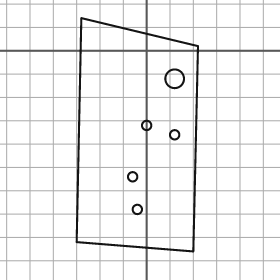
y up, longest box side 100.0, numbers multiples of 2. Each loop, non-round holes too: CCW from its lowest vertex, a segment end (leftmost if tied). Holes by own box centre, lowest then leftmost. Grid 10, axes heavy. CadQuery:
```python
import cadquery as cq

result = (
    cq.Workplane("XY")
    .moveTo(20.0, -86.0)
    .lineTo(22.0, 2.0)
    .lineTo(-28.0, 14.0)
    .lineTo(-30.0, -82.0)
    .close()
    .moveTo(-4.0, -68.0)
    .circle(2.0)
    .moveTo(-6.0, -54.0)
    .circle(2.0)
    .moveTo(12.0, -36.0)
    .circle(2.0)
    .moveTo(0.0, -32.0)
    .circle(2.0)
    .moveTo(12.0, -12.0)
    .circle(4.0)
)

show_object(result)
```